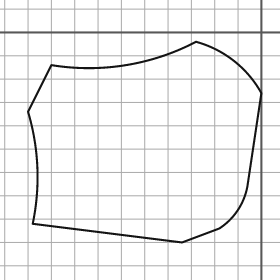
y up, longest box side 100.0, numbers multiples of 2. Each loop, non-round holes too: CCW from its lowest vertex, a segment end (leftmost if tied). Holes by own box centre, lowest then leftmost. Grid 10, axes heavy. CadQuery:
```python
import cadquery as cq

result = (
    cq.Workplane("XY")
    .moveTo(-34.0, -90.0)
    .lineTo(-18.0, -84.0)
    .threePointArc((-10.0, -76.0), (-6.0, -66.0))
    .lineTo(0.0, -26.0)
    .threePointArc((-12.0, -12.0), (-28.0, -4.0))
    .threePointArc((-58.0, -14.0), (-90.0, -14.0))
    .lineTo(-100.0, -34.0)
    .threePointArc((-96.0, -58.0), (-98.0, -82.0))
    .close()
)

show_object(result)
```